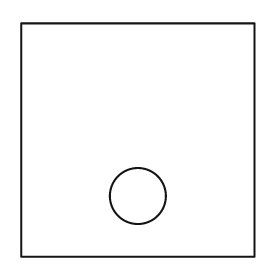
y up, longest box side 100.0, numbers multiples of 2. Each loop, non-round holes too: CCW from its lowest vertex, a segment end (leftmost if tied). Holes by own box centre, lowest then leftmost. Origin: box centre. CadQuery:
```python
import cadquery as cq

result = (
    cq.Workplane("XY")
    .moveTo(-50.0, -50.0)
    .lineTo(50.0, -50.0)
    .lineTo(50.0, 50.0)
    .lineTo(-50.0, 50.0)
    .close()
    .moveTo(0.0, -24.0)
    .circle(12.0)
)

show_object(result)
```